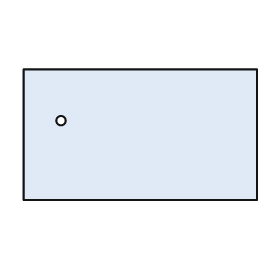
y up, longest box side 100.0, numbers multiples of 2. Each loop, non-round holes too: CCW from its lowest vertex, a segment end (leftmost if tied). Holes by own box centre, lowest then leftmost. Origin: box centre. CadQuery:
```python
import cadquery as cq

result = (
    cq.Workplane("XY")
    .moveTo(-50.0, -28.0)
    .lineTo(50.0, -28.0)
    .lineTo(50.0, 28.0)
    .lineTo(-50.0, 28.0)
    .close()
    .moveTo(-34.0, 6.0)
    .circle(2.0)
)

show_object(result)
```